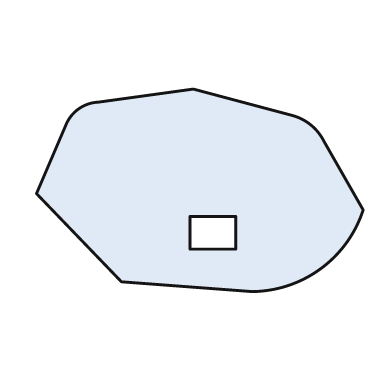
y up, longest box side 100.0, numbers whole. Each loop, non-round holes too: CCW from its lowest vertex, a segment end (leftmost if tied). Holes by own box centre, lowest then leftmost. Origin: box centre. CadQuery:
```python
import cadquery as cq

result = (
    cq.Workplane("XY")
    .moveTo(16.0, -31.0)
    .threePointArc((37.0, -24.0), (50.0, -6.0))
    .lineTo(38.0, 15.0)
    .threePointArc((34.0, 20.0), (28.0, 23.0))
    .lineTo(-2.0, 31.0)
    .lineTo(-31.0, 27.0)
    .threePointArc((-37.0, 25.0), (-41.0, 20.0))
    .lineTo(-50.0, -1.0)
    .lineTo(-24.0, -28.0)
    .close()
    .moveTo(-3.0, -18.0)
    .lineTo(11.0, -18.0)
    .lineTo(11.0, -8.0)
    .lineTo(-3.0, -8.0)
    .close()
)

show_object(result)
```